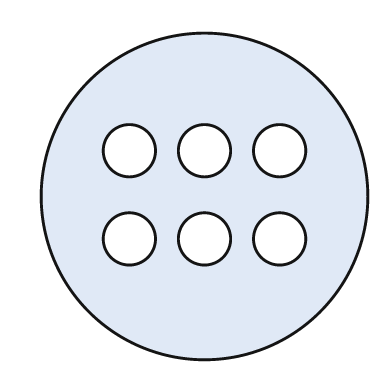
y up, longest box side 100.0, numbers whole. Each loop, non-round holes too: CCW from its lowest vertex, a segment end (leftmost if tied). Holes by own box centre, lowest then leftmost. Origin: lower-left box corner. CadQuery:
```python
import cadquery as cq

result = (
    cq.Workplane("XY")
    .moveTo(50.0, 50.0)
    .circle(50.0)
    .moveTo(27.0, 37.0)
    .circle(8.0)
    .moveTo(50.0, 37.0)
    .circle(8.0)
    .moveTo(73.0, 37.0)
    .circle(8.0)
    .moveTo(27.0, 64.0)
    .circle(8.0)
    .moveTo(50.0, 64.0)
    .circle(8.0)
    .moveTo(73.0, 64.0)
    .circle(8.0)
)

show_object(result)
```